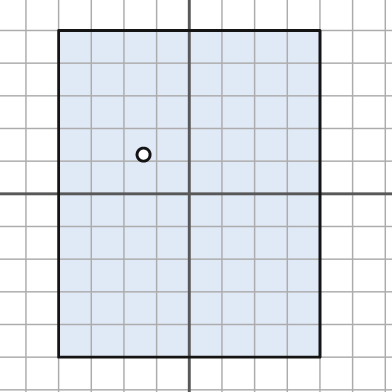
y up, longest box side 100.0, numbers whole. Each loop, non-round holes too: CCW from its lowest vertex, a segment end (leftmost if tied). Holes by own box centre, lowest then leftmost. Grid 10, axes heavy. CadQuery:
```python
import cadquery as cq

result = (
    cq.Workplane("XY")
    .moveTo(-40.0, -50.0)
    .lineTo(40.0, -50.0)
    .lineTo(40.0, 50.0)
    .lineTo(-40.0, 50.0)
    .close()
    .moveTo(-14.0, 12.0)
    .circle(2.0)
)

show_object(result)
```